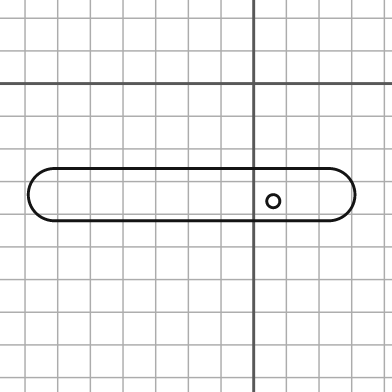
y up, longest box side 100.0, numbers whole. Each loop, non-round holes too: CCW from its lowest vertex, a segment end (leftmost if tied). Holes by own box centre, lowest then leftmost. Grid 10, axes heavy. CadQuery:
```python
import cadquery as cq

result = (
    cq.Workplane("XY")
    .moveTo(-61.0, -42.0)
    .lineTo(23.0, -42.0)
    .threePointArc((31.0, -34.0), (23.0, -26.0))
    .lineTo(-61.0, -26.0)
    .threePointArc((-69.0, -34.0), (-61.0, -42.0))
    .close()
    .moveTo(6.0, -36.0)
    .circle(2.0)
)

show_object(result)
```